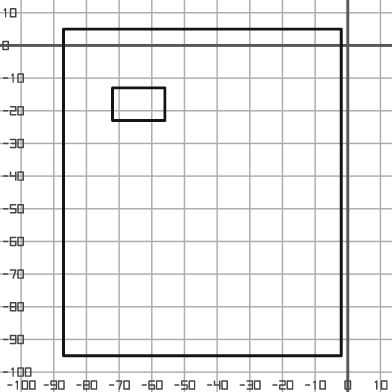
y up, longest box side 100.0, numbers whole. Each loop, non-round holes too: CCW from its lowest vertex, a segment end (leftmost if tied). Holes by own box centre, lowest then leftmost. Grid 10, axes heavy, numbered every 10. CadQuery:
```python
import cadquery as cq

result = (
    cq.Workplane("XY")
    .moveTo(-87.0, -95.0)
    .lineTo(-2.0, -95.0)
    .lineTo(-2.0, 5.0)
    .lineTo(-87.0, 5.0)
    .close()
    .moveTo(-72.0, -23.0)
    .lineTo(-56.0, -23.0)
    .lineTo(-56.0, -13.0)
    .lineTo(-72.0, -13.0)
    .close()
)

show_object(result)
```